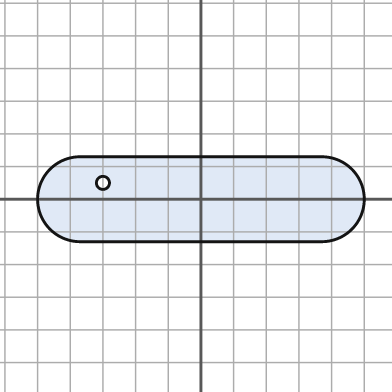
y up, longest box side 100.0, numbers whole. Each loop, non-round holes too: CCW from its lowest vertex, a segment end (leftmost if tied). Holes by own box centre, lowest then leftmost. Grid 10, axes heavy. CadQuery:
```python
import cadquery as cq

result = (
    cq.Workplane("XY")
    .moveTo(-37.0, -13.0)
    .lineTo(37.0, -13.0)
    .threePointArc((50.0, 0.0), (37.0, 13.0))
    .lineTo(-37.0, 13.0)
    .threePointArc((-50.0, 0.0), (-37.0, -13.0))
    .close()
    .moveTo(-30.0, 5.0)
    .circle(2.0)
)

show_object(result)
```